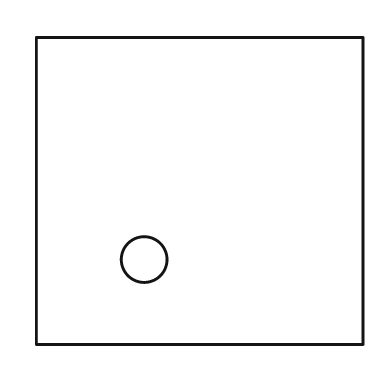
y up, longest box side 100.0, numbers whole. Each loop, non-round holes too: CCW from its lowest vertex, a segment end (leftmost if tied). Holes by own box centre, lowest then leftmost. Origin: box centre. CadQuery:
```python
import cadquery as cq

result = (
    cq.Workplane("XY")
    .moveTo(-50.0, -47.0)
    .lineTo(50.0, -47.0)
    .lineTo(50.0, 47.0)
    .lineTo(-50.0, 47.0)
    .close()
    .moveTo(-17.0, -21.0)
    .circle(7.0)
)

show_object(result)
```